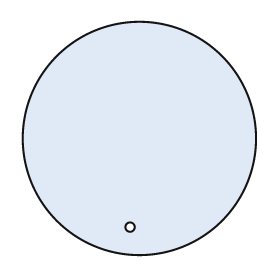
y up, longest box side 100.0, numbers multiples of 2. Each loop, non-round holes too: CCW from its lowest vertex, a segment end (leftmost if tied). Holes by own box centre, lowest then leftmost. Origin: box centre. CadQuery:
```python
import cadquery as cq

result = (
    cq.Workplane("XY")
    .moveTo(0.0, 0.0)
    .circle(50.0)
    .moveTo(-4.0, -38.0)
    .circle(2.0)
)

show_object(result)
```